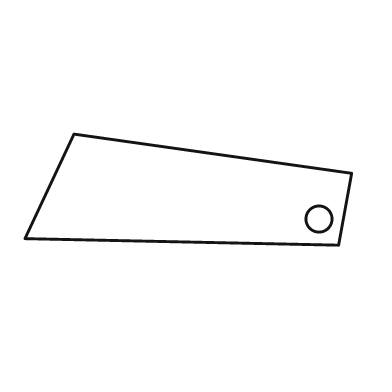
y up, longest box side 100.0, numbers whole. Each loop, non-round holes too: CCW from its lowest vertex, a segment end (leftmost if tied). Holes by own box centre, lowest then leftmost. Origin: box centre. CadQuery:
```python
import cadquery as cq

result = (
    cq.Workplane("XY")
    .moveTo(46.0, -17.0)
    .lineTo(50.0, 5.0)
    .lineTo(-35.0, 17.0)
    .lineTo(-50.0, -15.0)
    .close()
    .moveTo(40.0, -9.0)
    .circle(4.0)
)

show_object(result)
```